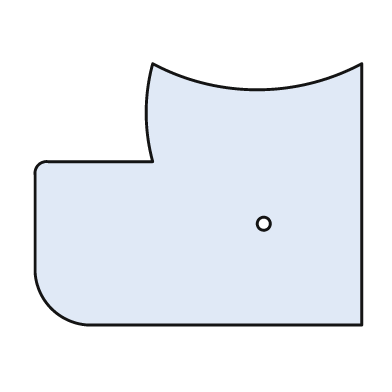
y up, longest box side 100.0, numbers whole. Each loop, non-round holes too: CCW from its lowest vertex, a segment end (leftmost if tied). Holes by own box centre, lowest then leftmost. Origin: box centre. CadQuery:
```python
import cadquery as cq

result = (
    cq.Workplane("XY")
    .moveTo(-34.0, -40.0)
    .lineTo(50.0, -40.0)
    .lineTo(50.0, 40.0)
    .threePointArc((18.0, 32.0), (-14.0, 40.0))
    .threePointArc((-16.0, 25.0), (-14.0, 10.0))
    .lineTo(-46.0, 10.0)
    .threePointArc((-49.0, 9.0), (-50.0, 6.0))
    .lineTo(-50.0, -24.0)
    .threePointArc((-45.0, -35.0), (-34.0, -40.0))
    .close()
    .moveTo(20.0, -9.0)
    .circle(2.0)
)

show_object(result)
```